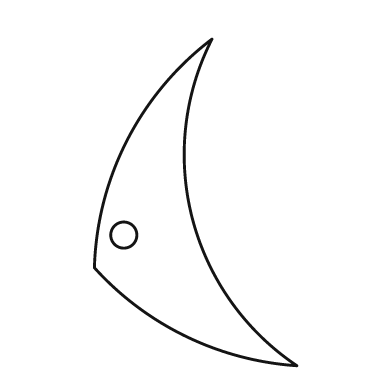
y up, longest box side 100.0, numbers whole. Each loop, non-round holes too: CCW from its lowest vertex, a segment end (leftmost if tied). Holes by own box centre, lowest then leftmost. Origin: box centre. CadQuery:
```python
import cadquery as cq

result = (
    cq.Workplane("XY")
    .moveTo(31.0, -50.0)
    .threePointArc((-1.0, -5.0), (5.0, 50.0))
    .threePointArc((-21.0, 19.0), (-31.0, -20.0))
    .threePointArc((-3.0, -41.0), (31.0, -50.0))
    .close()
    .moveTo(-22.0, -10.0)
    .circle(4.0)
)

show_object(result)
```